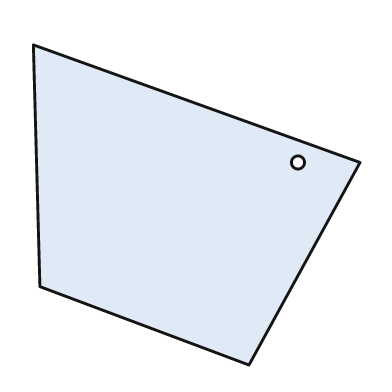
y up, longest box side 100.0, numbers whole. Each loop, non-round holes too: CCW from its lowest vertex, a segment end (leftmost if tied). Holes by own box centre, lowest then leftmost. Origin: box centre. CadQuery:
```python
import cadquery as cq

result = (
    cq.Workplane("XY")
    .moveTo(16.0, -49.0)
    .lineTo(50.0, 13.0)
    .lineTo(-50.0, 49.0)
    .lineTo(-48.0, -25.0)
    .close()
    .moveTo(31.0, 13.0)
    .circle(2.0)
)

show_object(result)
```